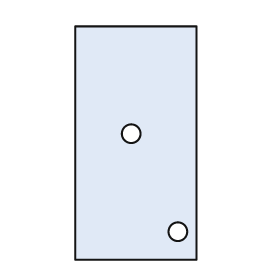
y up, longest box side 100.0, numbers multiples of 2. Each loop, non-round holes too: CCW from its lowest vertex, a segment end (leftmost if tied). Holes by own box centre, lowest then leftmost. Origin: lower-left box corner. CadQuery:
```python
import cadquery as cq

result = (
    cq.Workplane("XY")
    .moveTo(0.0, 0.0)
    .lineTo(52.0, 0.0)
    .lineTo(52.0, 100.0)
    .lineTo(0.0, 100.0)
    .close()
    .moveTo(44.0, 12.0)
    .circle(4.0)
    .moveTo(24.0, 54.0)
    .circle(4.0)
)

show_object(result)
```